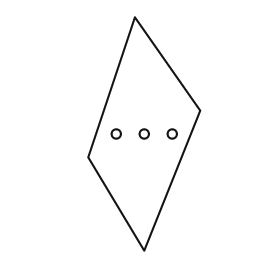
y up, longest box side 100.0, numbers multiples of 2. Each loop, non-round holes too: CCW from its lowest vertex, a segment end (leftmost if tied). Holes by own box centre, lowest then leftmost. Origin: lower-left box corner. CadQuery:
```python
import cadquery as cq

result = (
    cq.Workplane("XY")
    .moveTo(24.0, 0.0)
    .lineTo(48.0, 60.0)
    .lineTo(20.0, 100.0)
    .lineTo(0.0, 40.0)
    .close()
    .moveTo(12.0, 50.0)
    .circle(2.0)
    .moveTo(24.0, 50.0)
    .circle(2.0)
    .moveTo(36.0, 50.0)
    .circle(2.0)
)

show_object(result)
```